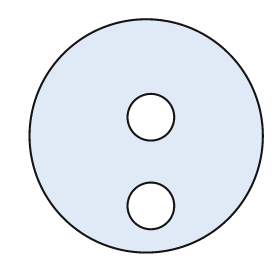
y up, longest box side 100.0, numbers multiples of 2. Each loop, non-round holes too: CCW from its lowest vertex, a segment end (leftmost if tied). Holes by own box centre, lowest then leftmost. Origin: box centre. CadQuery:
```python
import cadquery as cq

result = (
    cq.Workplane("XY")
    .moveTo(0.0, 0.0)
    .circle(50.0)
    .moveTo(2.0, -30.0)
    .circle(10.0)
    .moveTo(2.0, 8.0)
    .circle(10.0)
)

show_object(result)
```